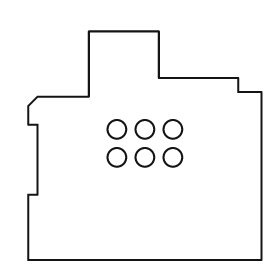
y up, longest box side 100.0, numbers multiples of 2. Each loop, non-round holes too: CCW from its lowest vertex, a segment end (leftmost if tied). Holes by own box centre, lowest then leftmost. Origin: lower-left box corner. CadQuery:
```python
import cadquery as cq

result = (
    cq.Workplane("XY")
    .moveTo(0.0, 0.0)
    .lineTo(100.0, 0.0)
    .lineTo(100.0, 72.0)
    .lineTo(90.0, 72.0)
    .lineTo(90.0, 78.0)
    .lineTo(56.0, 78.0)
    .lineTo(56.0, 98.0)
    .lineTo(26.0, 98.0)
    .lineTo(26.0, 70.0)
    .lineTo(4.0, 70.0)
    .lineTo(0.0, 66.0)
    .lineTo(0.0, 58.0)
    .lineTo(4.0, 58.0)
    .lineTo(4.0, 28.0)
    .lineTo(0.0, 28.0)
    .close()
    .moveTo(38.0, 44.0)
    .circle(4.0)
    .moveTo(50.0, 44.0)
    .circle(4.0)
    .moveTo(62.0, 44.0)
    .circle(4.0)
    .moveTo(38.0, 56.0)
    .circle(4.0)
    .moveTo(50.0, 56.0)
    .circle(4.0)
    .moveTo(62.0, 56.0)
    .circle(4.0)
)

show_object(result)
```